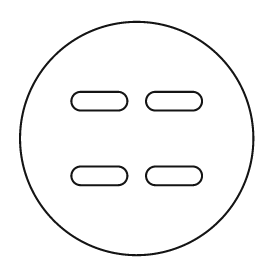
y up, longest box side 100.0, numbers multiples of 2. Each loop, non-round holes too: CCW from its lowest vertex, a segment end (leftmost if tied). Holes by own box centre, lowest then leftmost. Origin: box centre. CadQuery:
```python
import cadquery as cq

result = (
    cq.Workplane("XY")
    .moveTo(0.0, 0.0)
    .circle(50.0)
    .moveTo(-24.0, -20.0)
    .lineTo(-8.0, -20.0)
    .threePointArc((-4.0, -16.0), (-8.0, -12.0))
    .lineTo(-24.0, -12.0)
    .threePointArc((-28.0, -16.0), (-24.0, -20.0))
    .close()
    .moveTo(8.0, -20.0)
    .lineTo(24.0, -20.0)
    .threePointArc((28.0, -16.0), (24.0, -12.0))
    .lineTo(8.0, -12.0)
    .threePointArc((4.0, -16.0), (8.0, -20.0))
    .close()
    .moveTo(-24.0, 12.0)
    .lineTo(-8.0, 12.0)
    .threePointArc((-4.0, 16.0), (-8.0, 20.0))
    .lineTo(-24.0, 20.0)
    .threePointArc((-28.0, 16.0), (-24.0, 12.0))
    .close()
    .moveTo(8.0, 12.0)
    .lineTo(24.0, 12.0)
    .threePointArc((28.0, 16.0), (24.0, 20.0))
    .lineTo(8.0, 20.0)
    .threePointArc((4.0, 16.0), (8.0, 12.0))
    .close()
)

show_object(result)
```